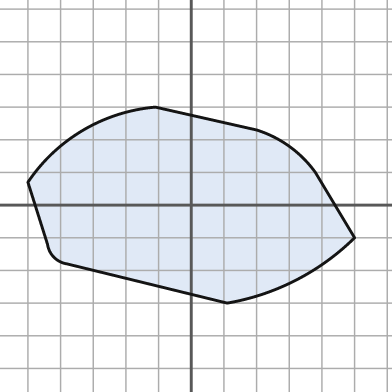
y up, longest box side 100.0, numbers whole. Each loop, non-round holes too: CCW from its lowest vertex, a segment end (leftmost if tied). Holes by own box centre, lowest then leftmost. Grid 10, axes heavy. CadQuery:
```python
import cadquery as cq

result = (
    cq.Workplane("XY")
    .moveTo(11.0, -30.0)
    .threePointArc((32.0, -23.0), (50.0, -10.0))
    .lineTo(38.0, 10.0)
    .threePointArc((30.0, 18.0), (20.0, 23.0))
    .lineTo(-11.0, 30.0)
    .threePointArc((-33.0, 23.0), (-50.0, 7.0))
    .lineTo(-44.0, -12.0)
    .threePointArc((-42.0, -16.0), (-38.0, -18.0))
    .close()
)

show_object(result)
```